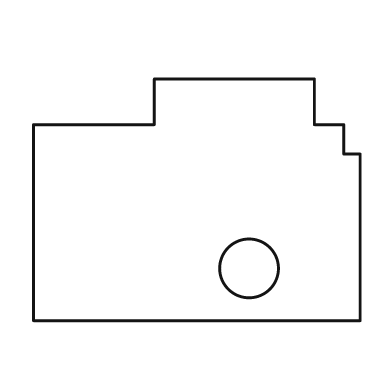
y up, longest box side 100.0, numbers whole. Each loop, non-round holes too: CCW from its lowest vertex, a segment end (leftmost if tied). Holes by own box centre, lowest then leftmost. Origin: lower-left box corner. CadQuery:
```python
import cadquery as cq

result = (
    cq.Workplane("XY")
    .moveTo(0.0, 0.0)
    .lineTo(100.0, 0.0)
    .lineTo(100.0, 51.0)
    .lineTo(95.0, 51.0)
    .lineTo(95.0, 60.0)
    .lineTo(86.0, 60.0)
    .lineTo(86.0, 74.0)
    .lineTo(37.0, 74.0)
    .lineTo(37.0, 60.0)
    .lineTo(0.0, 60.0)
    .close()
    .moveTo(66.0, 16.0)
    .circle(9.0)
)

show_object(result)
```